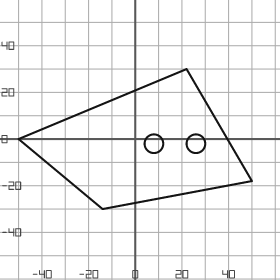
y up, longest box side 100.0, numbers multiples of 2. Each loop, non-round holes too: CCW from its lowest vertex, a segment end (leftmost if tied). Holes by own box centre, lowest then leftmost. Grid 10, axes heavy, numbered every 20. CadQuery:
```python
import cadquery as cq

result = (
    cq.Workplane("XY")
    .moveTo(-14.0, -30.0)
    .lineTo(50.0, -18.0)
    .lineTo(22.0, 30.0)
    .lineTo(-50.0, 0.0)
    .close()
    .moveTo(8.0, -2.0)
    .circle(4.0)
    .moveTo(26.0, -2.0)
    .circle(4.0)
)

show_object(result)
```